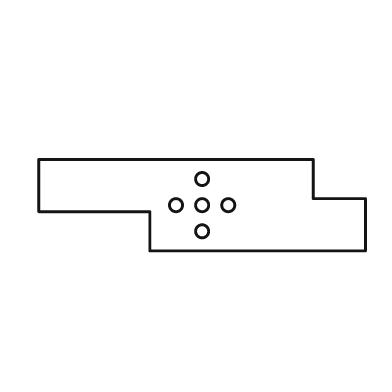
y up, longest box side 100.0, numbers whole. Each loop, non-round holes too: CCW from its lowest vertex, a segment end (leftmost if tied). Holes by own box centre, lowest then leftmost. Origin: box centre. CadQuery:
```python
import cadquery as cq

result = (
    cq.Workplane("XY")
    .moveTo(-16.0, -14.0)
    .lineTo(50.0, -14.0)
    .lineTo(50.0, 2.0)
    .lineTo(34.0, 2.0)
    .lineTo(34.0, 14.0)
    .lineTo(-50.0, 14.0)
    .lineTo(-50.0, -2.0)
    .lineTo(-16.0, -2.0)
    .close()
    .moveTo(0.0, -8.0)
    .circle(2.0)
    .moveTo(-8.0, 0.0)
    .circle(2.0)
    .moveTo(0.0, 0.0)
    .circle(2.0)
    .moveTo(8.0, 0.0)
    .circle(2.0)
    .moveTo(0.0, 8.0)
    .circle(2.0)
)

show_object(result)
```